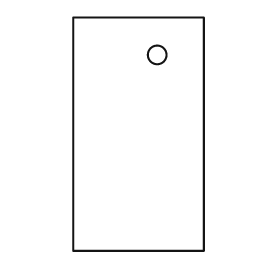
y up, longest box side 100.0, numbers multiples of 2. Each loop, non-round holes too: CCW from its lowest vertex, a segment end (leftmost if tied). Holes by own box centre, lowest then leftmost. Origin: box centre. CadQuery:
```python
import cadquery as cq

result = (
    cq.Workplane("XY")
    .moveTo(-28.0, -50.0)
    .lineTo(28.0, -50.0)
    .lineTo(28.0, 50.0)
    .lineTo(-28.0, 50.0)
    .close()
    .moveTo(8.0, 34.0)
    .circle(4.0)
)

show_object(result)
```